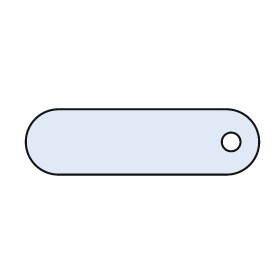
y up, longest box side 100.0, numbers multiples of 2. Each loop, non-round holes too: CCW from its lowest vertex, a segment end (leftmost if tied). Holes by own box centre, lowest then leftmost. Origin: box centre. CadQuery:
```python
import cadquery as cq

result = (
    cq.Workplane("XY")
    .moveTo(-36.0, -14.0)
    .lineTo(36.0, -14.0)
    .threePointArc((50.0, 0.0), (36.0, 14.0))
    .lineTo(-36.0, 14.0)
    .threePointArc((-50.0, 0.0), (-36.0, -14.0))
    .close()
    .moveTo(38.0, 0.0)
    .circle(4.0)
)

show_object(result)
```